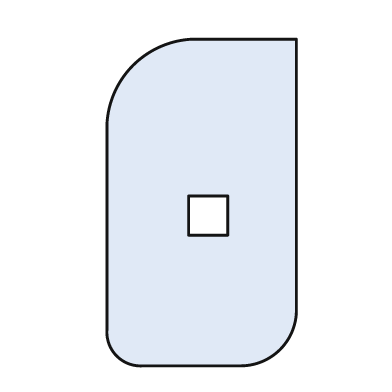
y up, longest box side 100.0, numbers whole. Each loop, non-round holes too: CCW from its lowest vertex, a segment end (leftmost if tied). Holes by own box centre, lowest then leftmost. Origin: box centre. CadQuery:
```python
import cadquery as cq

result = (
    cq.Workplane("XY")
    .moveTo(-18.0, -50.0)
    .lineTo(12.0, -50.0)
    .threePointArc((24.0, -45.0), (29.0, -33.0))
    .lineTo(29.0, 50.0)
    .lineTo(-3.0, 50.0)
    .threePointArc((-21.0, 42.0), (-29.0, 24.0))
    .lineTo(-29.0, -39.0)
    .threePointArc((-26.0, -47.0), (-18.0, -50.0))
    .close()
    .moveTo(-4.0, -10.0)
    .lineTo(8.0, -10.0)
    .lineTo(8.0, 2.0)
    .lineTo(-4.0, 2.0)
    .close()
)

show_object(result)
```